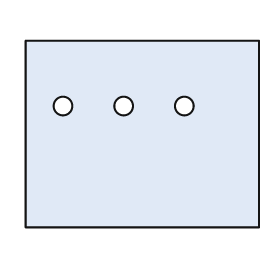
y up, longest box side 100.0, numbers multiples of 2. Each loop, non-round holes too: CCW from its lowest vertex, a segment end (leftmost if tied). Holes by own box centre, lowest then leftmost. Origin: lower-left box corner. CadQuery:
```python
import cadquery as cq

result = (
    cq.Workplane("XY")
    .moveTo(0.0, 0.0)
    .lineTo(100.0, 0.0)
    .lineTo(100.0, 80.0)
    .lineTo(0.0, 80.0)
    .close()
    .moveTo(16.0, 52.0)
    .circle(4.0)
    .moveTo(42.0, 52.0)
    .circle(4.0)
    .moveTo(68.0, 52.0)
    .circle(4.0)
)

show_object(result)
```